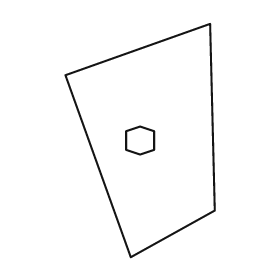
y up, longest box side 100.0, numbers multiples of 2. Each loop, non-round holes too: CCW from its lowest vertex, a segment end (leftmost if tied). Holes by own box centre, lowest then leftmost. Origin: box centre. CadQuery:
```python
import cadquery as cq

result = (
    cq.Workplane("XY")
    .moveTo(-4.0, -50.0)
    .lineTo(32.0, -30.0)
    .lineTo(30.0, 50.0)
    .lineTo(-32.0, 28.0)
    .close()
    .moveTo(0.0, -6.0)
    .lineTo(6.0, -4.0)
    .lineTo(6.0, 4.0)
    .lineTo(0.0, 6.0)
    .lineTo(-6.0, 4.0)
    .lineTo(-6.0, -4.0)
    .close()
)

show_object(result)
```